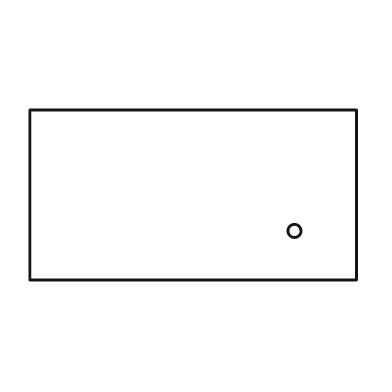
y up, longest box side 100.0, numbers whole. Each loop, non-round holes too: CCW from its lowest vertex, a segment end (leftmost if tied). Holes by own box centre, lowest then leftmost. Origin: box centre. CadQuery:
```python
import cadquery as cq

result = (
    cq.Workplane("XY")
    .moveTo(-50.0, -26.0)
    .lineTo(50.0, -26.0)
    .lineTo(50.0, 26.0)
    .lineTo(-50.0, 26.0)
    .close()
    .moveTo(31.0, -11.0)
    .circle(2.0)
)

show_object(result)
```